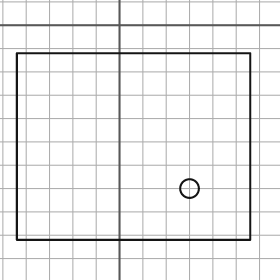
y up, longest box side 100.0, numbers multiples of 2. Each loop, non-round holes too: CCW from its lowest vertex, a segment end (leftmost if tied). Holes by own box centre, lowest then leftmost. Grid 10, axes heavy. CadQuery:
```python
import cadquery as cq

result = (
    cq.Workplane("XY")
    .moveTo(-44.0, -92.0)
    .lineTo(56.0, -92.0)
    .lineTo(56.0, -12.0)
    .lineTo(-44.0, -12.0)
    .close()
    .moveTo(30.0, -70.0)
    .circle(4.0)
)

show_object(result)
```